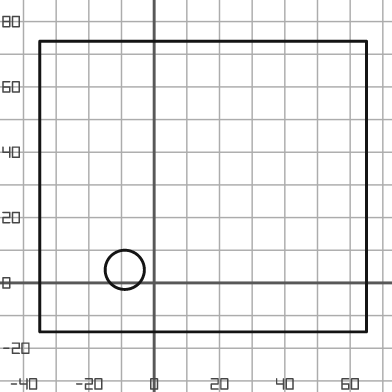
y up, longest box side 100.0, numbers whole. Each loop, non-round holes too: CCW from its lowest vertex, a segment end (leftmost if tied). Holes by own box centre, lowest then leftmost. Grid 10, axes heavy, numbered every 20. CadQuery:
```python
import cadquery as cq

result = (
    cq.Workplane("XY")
    .moveTo(-35.0, -15.0)
    .lineTo(65.0, -15.0)
    .lineTo(65.0, 74.0)
    .lineTo(-35.0, 74.0)
    .close()
    .moveTo(-9.0, 4.0)
    .circle(6.0)
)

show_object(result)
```